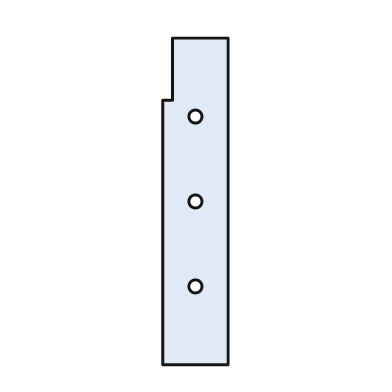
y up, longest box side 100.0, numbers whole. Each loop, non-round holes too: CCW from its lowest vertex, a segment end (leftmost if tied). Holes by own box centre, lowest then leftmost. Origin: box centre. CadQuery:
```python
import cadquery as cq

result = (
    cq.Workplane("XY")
    .moveTo(-10.0, -50.0)
    .lineTo(10.0, -50.0)
    .lineTo(10.0, 50.0)
    .lineTo(-7.0, 50.0)
    .lineTo(-7.0, 31.0)
    .lineTo(-10.0, 31.0)
    .close()
    .moveTo(0.0, -26.0)
    .circle(2.0)
    .moveTo(0.0, 0.0)
    .circle(2.0)
    .moveTo(0.0, 26.0)
    .circle(2.0)
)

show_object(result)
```